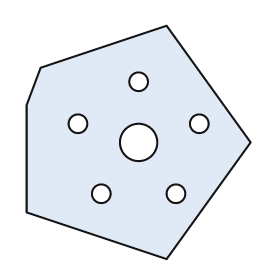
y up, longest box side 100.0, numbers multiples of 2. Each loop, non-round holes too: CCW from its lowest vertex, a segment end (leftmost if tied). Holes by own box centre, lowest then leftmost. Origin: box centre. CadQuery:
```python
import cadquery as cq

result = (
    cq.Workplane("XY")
    .moveTo(12.0, -50.0)
    .lineTo(48.0, 0.0)
    .lineTo(12.0, 50.0)
    .lineTo(-42.0, 32.0)
    .lineTo(-48.0, 16.0)
    .lineTo(-48.0, -30.0)
    .close()
    .moveTo(-16.0, -22.0)
    .circle(4.0)
    .moveTo(16.0, -22.0)
    .circle(4.0)
    .moveTo(0.0, 0.0)
    .circle(8.0)
    .moveTo(-26.0, 8.0)
    .circle(4.0)
    .moveTo(26.0, 8.0)
    .circle(4.0)
    .moveTo(0.0, 26.0)
    .circle(4.0)
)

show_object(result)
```